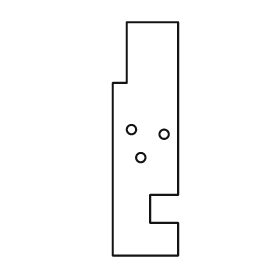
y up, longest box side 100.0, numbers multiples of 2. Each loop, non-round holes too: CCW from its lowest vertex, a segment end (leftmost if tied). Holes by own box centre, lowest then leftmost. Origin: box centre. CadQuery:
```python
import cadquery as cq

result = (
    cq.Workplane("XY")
    .moveTo(-14.0, -50.0)
    .lineTo(14.0, -50.0)
    .lineTo(14.0, -36.0)
    .lineTo(2.0, -36.0)
    .lineTo(2.0, -24.0)
    .lineTo(14.0, -24.0)
    .lineTo(14.0, 50.0)
    .lineTo(-8.0, 50.0)
    .lineTo(-8.0, 24.0)
    .lineTo(-14.0, 24.0)
    .close()
    .moveTo(-2.0, -8.0)
    .circle(2.0)
    .moveTo(8.0, 2.0)
    .circle(2.0)
    .moveTo(-6.0, 4.0)
    .circle(2.0)
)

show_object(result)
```